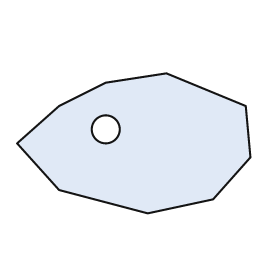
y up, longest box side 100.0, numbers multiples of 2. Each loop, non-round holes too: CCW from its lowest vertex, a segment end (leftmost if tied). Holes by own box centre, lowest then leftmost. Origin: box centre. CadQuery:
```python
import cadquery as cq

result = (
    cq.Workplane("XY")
    .moveTo(6.0, -30.0)
    .lineTo(34.0, -24.0)
    .lineTo(50.0, -6.0)
    .lineTo(48.0, 16.0)
    .lineTo(14.0, 30.0)
    .lineTo(-12.0, 26.0)
    .lineTo(-32.0, 16.0)
    .lineTo(-50.0, 0.0)
    .lineTo(-32.0, -20.0)
    .close()
    .moveTo(-12.0, 6.0)
    .circle(6.0)
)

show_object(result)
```